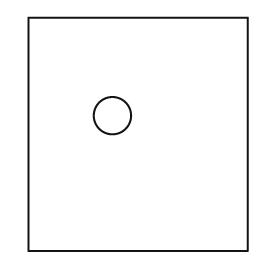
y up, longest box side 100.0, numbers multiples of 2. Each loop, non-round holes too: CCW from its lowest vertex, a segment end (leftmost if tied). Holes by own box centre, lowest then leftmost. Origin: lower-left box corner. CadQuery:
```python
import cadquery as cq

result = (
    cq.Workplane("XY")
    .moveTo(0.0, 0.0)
    .lineTo(94.0, 0.0)
    .lineTo(94.0, 100.0)
    .lineTo(0.0, 100.0)
    .close()
    .moveTo(36.0, 58.0)
    .circle(8.0)
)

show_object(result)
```